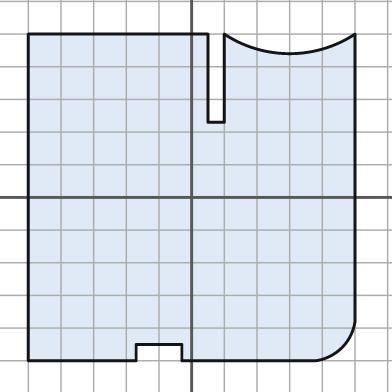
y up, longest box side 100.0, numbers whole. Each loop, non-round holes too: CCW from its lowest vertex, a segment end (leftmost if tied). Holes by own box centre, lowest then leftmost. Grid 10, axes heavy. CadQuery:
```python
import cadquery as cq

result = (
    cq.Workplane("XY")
    .moveTo(-50.0, -50.0)
    .lineTo(-17.0, -50.0)
    .lineTo(-17.0, -45.0)
    .lineTo(-3.0, -45.0)
    .lineTo(-3.0, -50.0)
    .lineTo(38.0, -50.0)
    .threePointArc((46.0, -46.0), (50.0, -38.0))
    .lineTo(50.0, 50.0)
    .threePointArc((30.0, 44.0), (10.0, 50.0))
    .lineTo(10.0, 23.0)
    .lineTo(5.0, 23.0)
    .lineTo(5.0, 50.0)
    .lineTo(-50.0, 50.0)
    .close()
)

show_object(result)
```